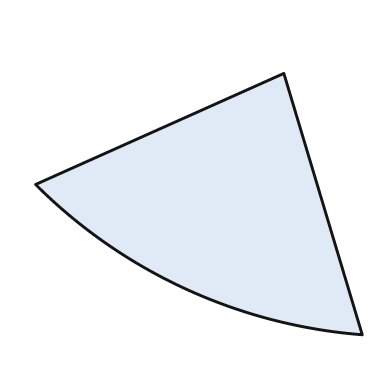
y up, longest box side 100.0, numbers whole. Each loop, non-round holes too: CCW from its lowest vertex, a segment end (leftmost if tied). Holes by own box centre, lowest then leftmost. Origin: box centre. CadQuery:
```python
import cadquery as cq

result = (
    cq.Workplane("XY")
    .moveTo(50.0, -40.0)
    .lineTo(26.0, 40.0)
    .lineTo(-50.0, 6.0)
    .threePointArc((-4.0, -26.0), (50.0, -40.0))
    .close()
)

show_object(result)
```